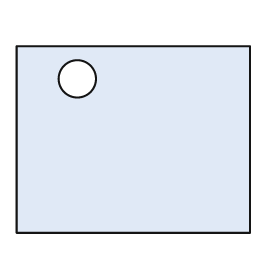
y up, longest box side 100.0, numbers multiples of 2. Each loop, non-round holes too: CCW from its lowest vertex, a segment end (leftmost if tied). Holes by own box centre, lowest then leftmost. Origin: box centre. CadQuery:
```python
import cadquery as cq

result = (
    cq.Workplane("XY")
    .moveTo(-50.0, -40.0)
    .lineTo(50.0, -40.0)
    .lineTo(50.0, 40.0)
    .lineTo(-50.0, 40.0)
    .close()
    .moveTo(-24.0, 26.0)
    .circle(8.0)
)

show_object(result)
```